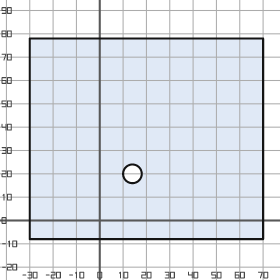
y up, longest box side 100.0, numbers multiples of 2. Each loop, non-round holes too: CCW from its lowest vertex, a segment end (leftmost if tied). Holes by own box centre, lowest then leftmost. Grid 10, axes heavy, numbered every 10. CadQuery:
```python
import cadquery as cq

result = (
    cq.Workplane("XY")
    .moveTo(-30.0, -8.0)
    .lineTo(70.0, -8.0)
    .lineTo(70.0, 78.0)
    .lineTo(-30.0, 78.0)
    .close()
    .moveTo(14.0, 20.0)
    .circle(4.0)
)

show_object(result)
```